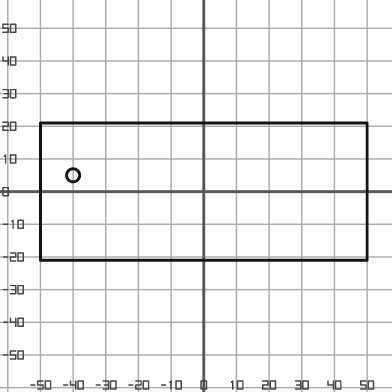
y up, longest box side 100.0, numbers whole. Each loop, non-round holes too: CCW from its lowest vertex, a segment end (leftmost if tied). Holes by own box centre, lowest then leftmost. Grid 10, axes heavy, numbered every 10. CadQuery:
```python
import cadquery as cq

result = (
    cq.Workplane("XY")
    .moveTo(-50.0, -21.0)
    .lineTo(50.0, -21.0)
    .lineTo(50.0, 21.0)
    .lineTo(-50.0, 21.0)
    .close()
    .moveTo(-40.0, 5.0)
    .circle(2.0)
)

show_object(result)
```